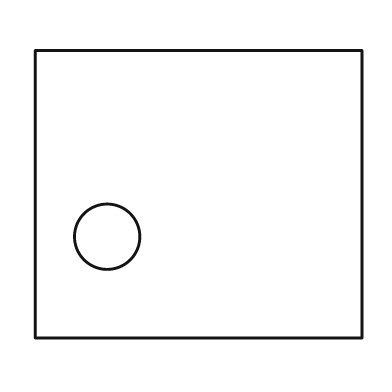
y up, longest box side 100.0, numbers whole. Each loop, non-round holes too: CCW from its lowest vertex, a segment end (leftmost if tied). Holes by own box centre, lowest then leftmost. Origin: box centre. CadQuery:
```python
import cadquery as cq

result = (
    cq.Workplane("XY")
    .moveTo(-50.0, -44.0)
    .lineTo(50.0, -44.0)
    .lineTo(50.0, 44.0)
    .lineTo(-50.0, 44.0)
    .close()
    .moveTo(-28.0, -13.0)
    .circle(10.0)
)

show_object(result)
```